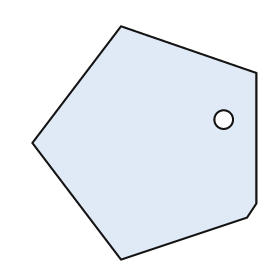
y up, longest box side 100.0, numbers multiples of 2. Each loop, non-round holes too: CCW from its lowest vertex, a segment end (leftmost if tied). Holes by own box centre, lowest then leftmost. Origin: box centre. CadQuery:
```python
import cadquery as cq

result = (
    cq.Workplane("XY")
    .moveTo(-10.0, -50.0)
    .lineTo(44.0, -32.0)
    .lineTo(48.0, -26.0)
    .lineTo(48.0, 30.0)
    .lineTo(-10.0, 50.0)
    .lineTo(-48.0, 0.0)
    .close()
    .moveTo(34.0, 10.0)
    .circle(4.0)
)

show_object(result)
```